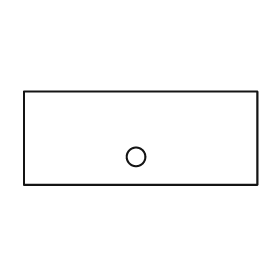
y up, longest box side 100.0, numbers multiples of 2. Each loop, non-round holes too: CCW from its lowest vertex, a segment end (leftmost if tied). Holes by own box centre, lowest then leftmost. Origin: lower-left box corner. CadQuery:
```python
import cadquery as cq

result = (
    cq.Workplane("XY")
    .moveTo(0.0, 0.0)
    .lineTo(100.0, 0.0)
    .lineTo(100.0, 40.0)
    .lineTo(0.0, 40.0)
    .close()
    .moveTo(48.0, 12.0)
    .circle(4.0)
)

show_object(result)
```